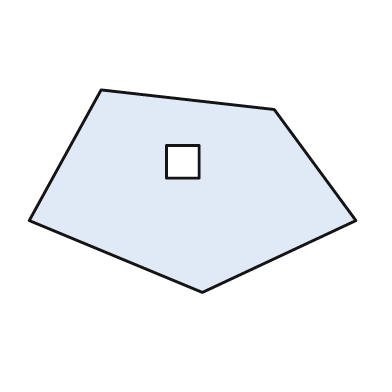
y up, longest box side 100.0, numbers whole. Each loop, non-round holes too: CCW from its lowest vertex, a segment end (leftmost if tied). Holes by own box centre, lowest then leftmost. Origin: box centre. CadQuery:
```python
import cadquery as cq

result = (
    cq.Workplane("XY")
    .moveTo(3.0, -31.0)
    .lineTo(50.0, -9.0)
    .lineTo(25.0, 25.0)
    .lineTo(-28.0, 31.0)
    .lineTo(-50.0, -9.0)
    .close()
    .moveTo(-8.0, 4.0)
    .lineTo(2.0, 4.0)
    .lineTo(2.0, 14.0)
    .lineTo(-8.0, 14.0)
    .close()
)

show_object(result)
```